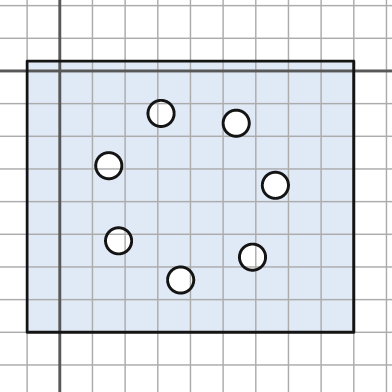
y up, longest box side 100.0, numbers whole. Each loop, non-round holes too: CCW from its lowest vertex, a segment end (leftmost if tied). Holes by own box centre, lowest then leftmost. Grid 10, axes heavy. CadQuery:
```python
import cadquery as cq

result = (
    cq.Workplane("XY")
    .moveTo(-10.0, -80.0)
    .lineTo(90.0, -80.0)
    .lineTo(90.0, 3.0)
    .lineTo(-10.0, 3.0)
    .close()
    .moveTo(37.0, -64.0)
    .circle(4.0)
    .moveTo(59.0, -57.0)
    .circle(4.0)
    .moveTo(18.0, -52.0)
    .circle(4.0)
    .moveTo(66.0, -35.0)
    .circle(4.0)
    .moveTo(15.0, -29.0)
    .circle(4.0)
    .moveTo(54.0, -16.0)
    .circle(4.0)
    .moveTo(31.0, -13.0)
    .circle(4.0)
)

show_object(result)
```